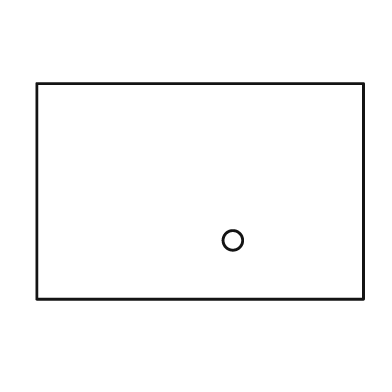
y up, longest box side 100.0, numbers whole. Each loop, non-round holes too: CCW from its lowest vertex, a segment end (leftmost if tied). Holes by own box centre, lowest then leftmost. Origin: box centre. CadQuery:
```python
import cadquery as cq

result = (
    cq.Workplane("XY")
    .moveTo(-50.0, -33.0)
    .lineTo(50.0, -33.0)
    .lineTo(50.0, 33.0)
    .lineTo(-50.0, 33.0)
    .close()
    .moveTo(10.0, -15.0)
    .circle(3.0)
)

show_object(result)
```